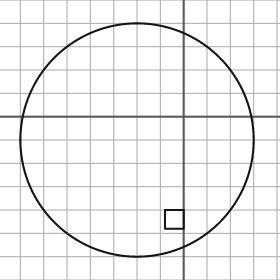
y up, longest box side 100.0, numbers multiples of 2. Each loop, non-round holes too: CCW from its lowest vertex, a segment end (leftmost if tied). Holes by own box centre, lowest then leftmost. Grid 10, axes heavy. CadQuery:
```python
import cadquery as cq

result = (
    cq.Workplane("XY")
    .moveTo(-20.0, -10.0)
    .circle(50.0)
    .moveTo(-8.0, -48.0)
    .lineTo(0.0, -48.0)
    .lineTo(0.0, -40.0)
    .lineTo(-8.0, -40.0)
    .close()
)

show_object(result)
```